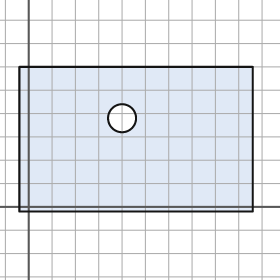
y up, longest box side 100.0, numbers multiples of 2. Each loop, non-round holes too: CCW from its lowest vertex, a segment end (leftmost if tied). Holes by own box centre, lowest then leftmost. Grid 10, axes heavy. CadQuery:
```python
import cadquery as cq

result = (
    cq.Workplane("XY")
    .moveTo(-4.0, -2.0)
    .lineTo(96.0, -2.0)
    .lineTo(96.0, 60.0)
    .lineTo(-4.0, 60.0)
    .close()
    .moveTo(40.0, 38.0)
    .circle(6.0)
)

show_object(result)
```